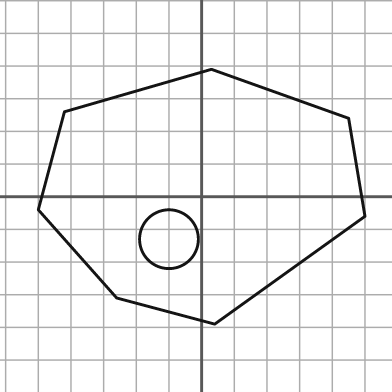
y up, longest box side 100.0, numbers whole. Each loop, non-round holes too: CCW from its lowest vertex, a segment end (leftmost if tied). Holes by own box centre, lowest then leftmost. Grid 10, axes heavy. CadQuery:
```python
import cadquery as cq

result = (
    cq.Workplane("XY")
    .moveTo(4.0, -39.0)
    .lineTo(50.0, -6.0)
    .lineTo(45.0, 24.0)
    .lineTo(3.0, 39.0)
    .lineTo(-42.0, 26.0)
    .lineTo(-50.0, -4.0)
    .lineTo(-26.0, -31.0)
    .close()
    .moveTo(-10.0, -13.0)
    .circle(9.0)
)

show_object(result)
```